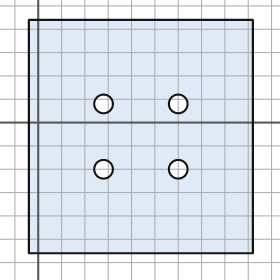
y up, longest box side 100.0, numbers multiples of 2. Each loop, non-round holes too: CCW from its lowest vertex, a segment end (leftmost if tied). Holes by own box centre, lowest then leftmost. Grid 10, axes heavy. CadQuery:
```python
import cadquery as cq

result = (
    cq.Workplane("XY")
    .moveTo(-4.0, -56.0)
    .lineTo(92.0, -56.0)
    .lineTo(92.0, 44.0)
    .lineTo(-4.0, 44.0)
    .close()
    .moveTo(28.0, -20.0)
    .circle(4.0)
    .moveTo(60.0, -20.0)
    .circle(4.0)
    .moveTo(28.0, 8.0)
    .circle(4.0)
    .moveTo(60.0, 8.0)
    .circle(4.0)
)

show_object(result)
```